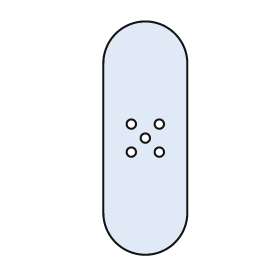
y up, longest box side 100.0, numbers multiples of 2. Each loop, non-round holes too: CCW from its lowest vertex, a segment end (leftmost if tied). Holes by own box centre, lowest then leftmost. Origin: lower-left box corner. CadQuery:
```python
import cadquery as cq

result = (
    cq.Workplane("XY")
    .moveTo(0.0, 18.0)
    .threePointArc((18.0, 0.0), (36.0, 18.0))
    .lineTo(36.0, 82.0)
    .threePointArc((18.0, 100.0), (0.0, 82.0))
    .close()
    .moveTo(12.0, 44.0)
    .circle(2.0)
    .moveTo(24.0, 44.0)
    .circle(2.0)
    .moveTo(18.0, 50.0)
    .circle(2.0)
    .moveTo(12.0, 56.0)
    .circle(2.0)
    .moveTo(24.0, 56.0)
    .circle(2.0)
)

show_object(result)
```